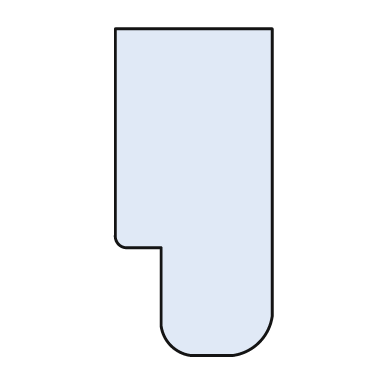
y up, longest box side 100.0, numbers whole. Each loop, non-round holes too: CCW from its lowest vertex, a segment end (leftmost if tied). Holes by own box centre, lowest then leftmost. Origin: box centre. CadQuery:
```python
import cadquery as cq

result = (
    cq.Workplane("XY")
    .moveTo(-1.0, -50.0)
    .lineTo(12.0, -50.0)
    .threePointArc((20.0, -46.0), (24.0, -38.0))
    .lineTo(24.0, 50.0)
    .lineTo(-24.0, 50.0)
    .lineTo(-24.0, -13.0)
    .threePointArc((-23.0, -16.0), (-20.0, -17.0))
    .lineTo(-10.0, -17.0)
    .lineTo(-10.0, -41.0)
    .threePointArc((-7.0, -47.0), (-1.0, -50.0))
    .close()
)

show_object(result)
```